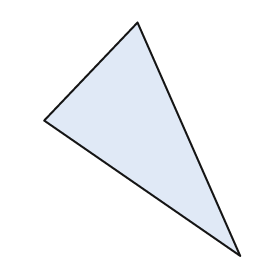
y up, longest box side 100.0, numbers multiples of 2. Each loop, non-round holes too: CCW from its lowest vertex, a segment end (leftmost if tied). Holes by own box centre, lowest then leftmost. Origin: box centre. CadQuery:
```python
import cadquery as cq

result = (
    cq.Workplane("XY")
    .moveTo(42.0, -50.0)
    .lineTo(-2.0, 50.0)
    .lineTo(-42.0, 8.0)
    .close()
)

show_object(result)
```